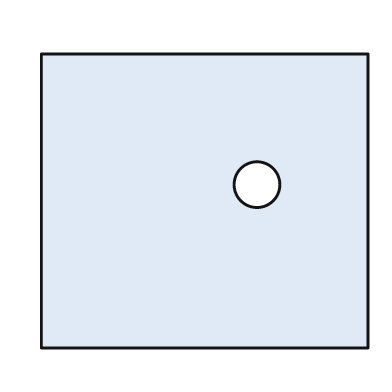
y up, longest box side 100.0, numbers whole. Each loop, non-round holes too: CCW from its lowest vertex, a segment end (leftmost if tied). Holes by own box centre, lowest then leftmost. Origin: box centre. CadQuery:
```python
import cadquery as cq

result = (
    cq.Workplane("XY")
    .moveTo(-50.0, -45.0)
    .lineTo(50.0, -45.0)
    .lineTo(50.0, 45.0)
    .lineTo(-50.0, 45.0)
    .close()
    .moveTo(16.0, 5.0)
    .circle(7.0)
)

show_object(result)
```